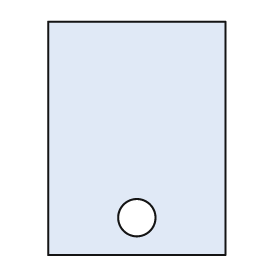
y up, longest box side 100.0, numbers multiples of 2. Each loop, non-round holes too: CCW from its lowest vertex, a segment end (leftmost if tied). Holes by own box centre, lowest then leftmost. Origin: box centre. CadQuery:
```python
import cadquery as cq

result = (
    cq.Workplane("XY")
    .moveTo(-38.0, -50.0)
    .lineTo(38.0, -50.0)
    .lineTo(38.0, 50.0)
    .lineTo(-38.0, 50.0)
    .close()
    .moveTo(0.0, -34.0)
    .circle(8.0)
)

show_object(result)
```